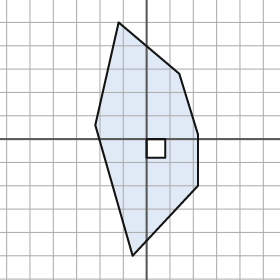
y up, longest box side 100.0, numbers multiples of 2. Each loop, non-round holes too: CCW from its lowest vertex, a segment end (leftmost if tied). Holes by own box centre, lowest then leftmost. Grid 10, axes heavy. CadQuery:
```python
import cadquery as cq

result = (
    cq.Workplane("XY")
    .moveTo(-6.0, -50.0)
    .lineTo(22.0, -20.0)
    .lineTo(22.0, 2.0)
    .lineTo(14.0, 28.0)
    .lineTo(-12.0, 50.0)
    .lineTo(-22.0, 6.0)
    .close()
    .moveTo(0.0, -8.0)
    .lineTo(8.0, -8.0)
    .lineTo(8.0, 0.0)
    .lineTo(0.0, 0.0)
    .close()
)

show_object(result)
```